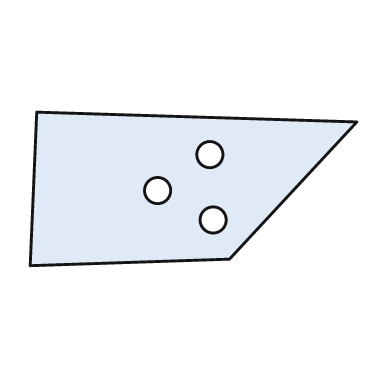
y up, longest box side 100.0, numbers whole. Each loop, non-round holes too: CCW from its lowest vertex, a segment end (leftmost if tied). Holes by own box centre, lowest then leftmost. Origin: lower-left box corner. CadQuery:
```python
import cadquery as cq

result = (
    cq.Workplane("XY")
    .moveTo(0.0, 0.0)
    .lineTo(61.0, 2.0)
    .lineTo(100.0, 44.0)
    .lineTo(2.0, 47.0)
    .close()
    .moveTo(56.0, 14.0)
    .circle(4.0)
    .moveTo(39.0, 23.0)
    .circle(4.0)
    .moveTo(55.0, 34.0)
    .circle(4.0)
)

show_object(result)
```